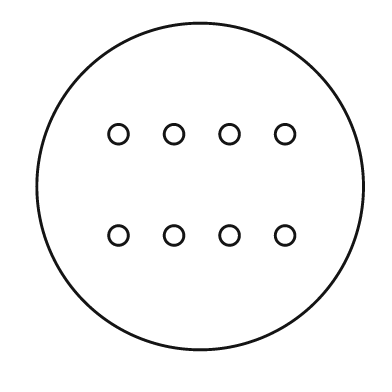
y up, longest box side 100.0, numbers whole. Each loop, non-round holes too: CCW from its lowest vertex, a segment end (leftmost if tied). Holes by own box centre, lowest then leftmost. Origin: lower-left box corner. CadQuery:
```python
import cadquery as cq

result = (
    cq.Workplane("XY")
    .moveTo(50.0, 50.0)
    .circle(50.0)
    .moveTo(25.0, 35.0)
    .circle(3.0)
    .moveTo(42.0, 35.0)
    .circle(3.0)
    .moveTo(59.0, 35.0)
    .circle(3.0)
    .moveTo(76.0, 35.0)
    .circle(3.0)
    .moveTo(25.0, 66.0)
    .circle(3.0)
    .moveTo(42.0, 66.0)
    .circle(3.0)
    .moveTo(59.0, 66.0)
    .circle(3.0)
    .moveTo(76.0, 66.0)
    .circle(3.0)
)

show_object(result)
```